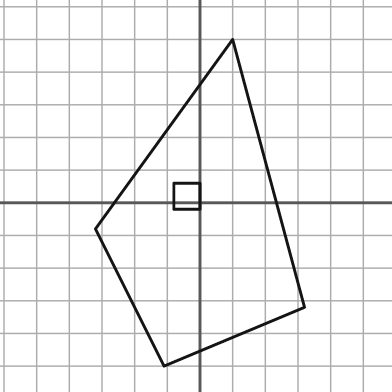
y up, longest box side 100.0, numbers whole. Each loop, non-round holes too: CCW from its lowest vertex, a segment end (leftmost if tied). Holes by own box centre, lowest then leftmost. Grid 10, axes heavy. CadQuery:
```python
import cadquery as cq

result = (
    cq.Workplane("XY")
    .moveTo(-11.0, -50.0)
    .lineTo(32.0, -32.0)
    .lineTo(10.0, 50.0)
    .lineTo(-32.0, -8.0)
    .close()
    .moveTo(-8.0, -2.0)
    .lineTo(0.0, -2.0)
    .lineTo(0.0, 6.0)
    .lineTo(-8.0, 6.0)
    .close()
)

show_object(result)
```